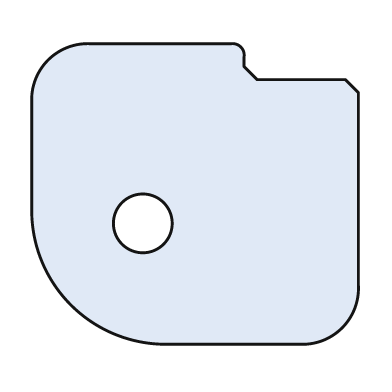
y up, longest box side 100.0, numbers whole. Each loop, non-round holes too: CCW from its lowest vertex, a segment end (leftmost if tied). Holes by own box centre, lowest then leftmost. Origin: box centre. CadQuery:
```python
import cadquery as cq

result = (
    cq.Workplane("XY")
    .moveTo(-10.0, -46.0)
    .lineTo(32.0, -46.0)
    .threePointArc((45.0, -41.0), (50.0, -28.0))
    .lineTo(50.0, 31.0)
    .lineTo(46.0, 35.0)
    .lineTo(19.0, 35.0)
    .lineTo(15.0, 39.0)
    .lineTo(15.0, 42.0)
    .threePointArc((14.0, 45.0), (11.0, 46.0))
    .lineTo(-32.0, 46.0)
    .threePointArc((-45.0, 41.0), (-50.0, 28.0))
    .lineTo(-50.0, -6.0)
    .threePointArc((-38.0, -34.0), (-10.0, -46.0))
    .close()
    .moveTo(-16.0, -9.0)
    .circle(9.0)
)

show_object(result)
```